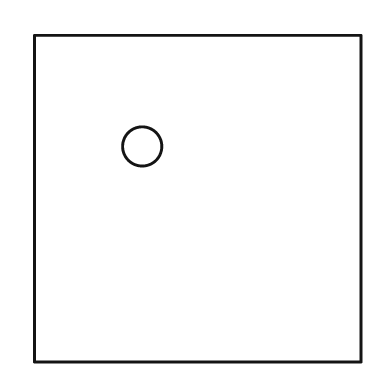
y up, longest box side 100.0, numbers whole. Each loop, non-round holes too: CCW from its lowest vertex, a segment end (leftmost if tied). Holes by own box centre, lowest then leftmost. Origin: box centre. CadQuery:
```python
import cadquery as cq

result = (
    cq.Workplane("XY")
    .moveTo(-50.0, -50.0)
    .lineTo(50.0, -50.0)
    .lineTo(50.0, 50.0)
    .lineTo(-50.0, 50.0)
    .close()
    .moveTo(-17.0, 16.0)
    .circle(6.0)
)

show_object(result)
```